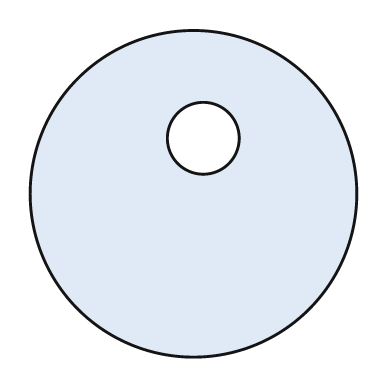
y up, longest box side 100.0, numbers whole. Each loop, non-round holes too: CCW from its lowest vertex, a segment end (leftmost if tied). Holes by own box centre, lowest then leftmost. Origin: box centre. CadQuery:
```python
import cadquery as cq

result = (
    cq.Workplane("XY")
    .moveTo(0.0, 0.0)
    .circle(50.0)
    .moveTo(3.0, 17.0)
    .circle(11.0)
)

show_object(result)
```